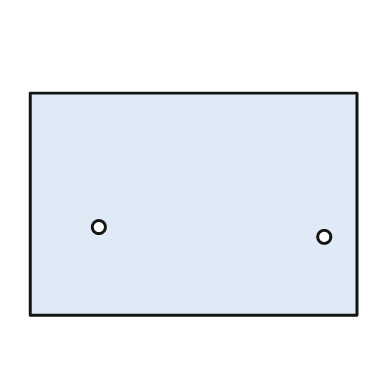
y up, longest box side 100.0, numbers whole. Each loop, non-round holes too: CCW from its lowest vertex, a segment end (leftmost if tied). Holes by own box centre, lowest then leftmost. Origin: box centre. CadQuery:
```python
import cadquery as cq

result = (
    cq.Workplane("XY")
    .moveTo(-50.0, -34.0)
    .lineTo(50.0, -34.0)
    .lineTo(50.0, 34.0)
    .lineTo(-50.0, 34.0)
    .close()
    .moveTo(40.0, -10.0)
    .circle(2.0)
    .moveTo(-29.0, -7.0)
    .circle(2.0)
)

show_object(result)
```